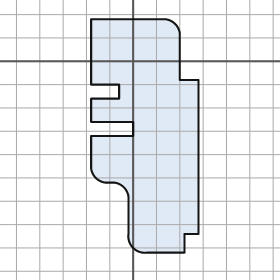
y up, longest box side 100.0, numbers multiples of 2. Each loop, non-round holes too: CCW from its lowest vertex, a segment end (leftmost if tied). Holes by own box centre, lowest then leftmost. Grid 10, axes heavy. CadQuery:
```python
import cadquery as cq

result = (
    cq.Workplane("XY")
    .moveTo(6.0, -82.0)
    .lineTo(22.0, -82.0)
    .lineTo(22.0, -74.0)
    .lineTo(28.0, -74.0)
    .lineTo(28.0, -8.0)
    .lineTo(20.0, -8.0)
    .lineTo(20.0, 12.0)
    .threePointArc((18.0, 16.0), (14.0, 18.0))
    .lineTo(-18.0, 18.0)
    .lineTo(-18.0, -10.0)
    .lineTo(-6.0, -10.0)
    .lineTo(-6.0, -16.0)
    .lineTo(-18.0, -16.0)
    .lineTo(-18.0, -26.0)
    .lineTo(0.0, -26.0)
    .lineTo(0.0, -32.0)
    .lineTo(-18.0, -32.0)
    .lineTo(-18.0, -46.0)
    .threePointArc((-16.0, -50.0), (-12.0, -52.0))
    .lineTo(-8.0, -52.0)
    .threePointArc((-4.0, -54.0), (-2.0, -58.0))
    .lineTo(-2.0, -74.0)
    .threePointArc((0.0, -80.0), (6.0, -82.0))
    .close()
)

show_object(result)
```